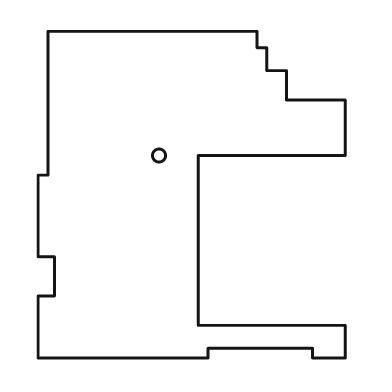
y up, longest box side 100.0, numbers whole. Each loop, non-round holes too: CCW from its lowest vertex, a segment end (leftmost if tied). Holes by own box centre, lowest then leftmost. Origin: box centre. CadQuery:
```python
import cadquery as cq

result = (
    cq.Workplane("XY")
    .moveTo(-47.0, -50.0)
    .lineTo(5.0, -50.0)
    .lineTo(5.0, -47.0)
    .lineTo(37.0, -47.0)
    .lineTo(37.0, -50.0)
    .lineTo(47.0, -50.0)
    .lineTo(47.0, -40.0)
    .lineTo(2.0, -40.0)
    .lineTo(2.0, 12.0)
    .lineTo(47.0, 12.0)
    .lineTo(47.0, 29.0)
    .lineTo(29.0, 29.0)
    .lineTo(29.0, 38.0)
    .lineTo(23.0, 38.0)
    .lineTo(23.0, 45.0)
    .lineTo(20.0, 45.0)
    .lineTo(20.0, 50.0)
    .lineTo(-44.0, 50.0)
    .lineTo(-44.0, 6.0)
    .lineTo(-47.0, 6.0)
    .lineTo(-47.0, -19.0)
    .lineTo(-42.0, -19.0)
    .lineTo(-42.0, -31.0)
    .lineTo(-47.0, -31.0)
    .close()
    .moveTo(-10.0, 12.0)
    .circle(2.0)
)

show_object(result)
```